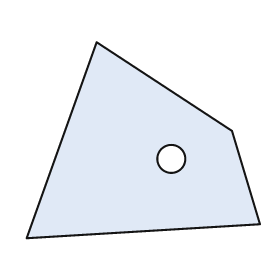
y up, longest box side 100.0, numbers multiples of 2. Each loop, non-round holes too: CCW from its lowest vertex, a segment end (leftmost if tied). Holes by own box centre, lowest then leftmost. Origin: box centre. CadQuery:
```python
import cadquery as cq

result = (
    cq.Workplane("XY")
    .moveTo(-50.0, -42.0)
    .lineTo(50.0, -36.0)
    .lineTo(38.0, 4.0)
    .lineTo(-20.0, 42.0)
    .close()
    .moveTo(12.0, -8.0)
    .circle(6.0)
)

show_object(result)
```